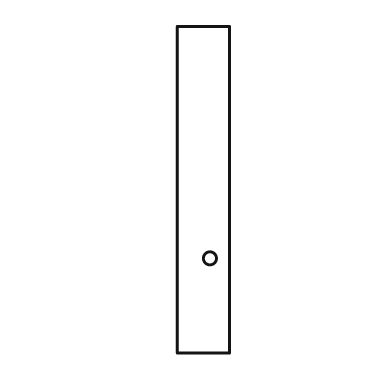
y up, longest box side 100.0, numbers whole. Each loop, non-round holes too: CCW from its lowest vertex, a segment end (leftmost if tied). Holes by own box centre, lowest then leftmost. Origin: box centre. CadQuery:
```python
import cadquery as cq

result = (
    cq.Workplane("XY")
    .moveTo(-8.0, -50.0)
    .lineTo(8.0, -50.0)
    .lineTo(8.0, 50.0)
    .lineTo(-8.0, 50.0)
    .close()
    .moveTo(2.0, -21.0)
    .circle(2.0)
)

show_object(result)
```